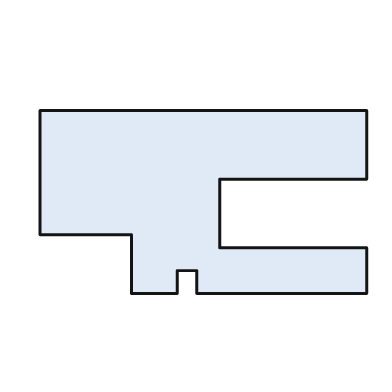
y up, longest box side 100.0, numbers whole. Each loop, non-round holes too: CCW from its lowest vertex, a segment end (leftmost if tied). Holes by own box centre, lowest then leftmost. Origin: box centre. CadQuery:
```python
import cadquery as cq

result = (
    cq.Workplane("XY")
    .moveTo(-22.0, -28.0)
    .lineTo(-8.0, -28.0)
    .lineTo(-8.0, -21.0)
    .lineTo(-2.0, -21.0)
    .lineTo(-2.0, -28.0)
    .lineTo(50.0, -28.0)
    .lineTo(50.0, -14.0)
    .lineTo(5.0, -14.0)
    .lineTo(5.0, 7.0)
    .lineTo(50.0, 7.0)
    .lineTo(50.0, 28.0)
    .lineTo(-50.0, 28.0)
    .lineTo(-50.0, -10.0)
    .lineTo(-22.0, -10.0)
    .close()
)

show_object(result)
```